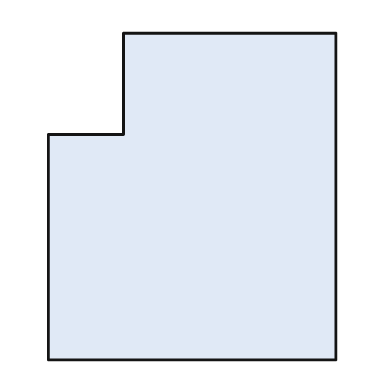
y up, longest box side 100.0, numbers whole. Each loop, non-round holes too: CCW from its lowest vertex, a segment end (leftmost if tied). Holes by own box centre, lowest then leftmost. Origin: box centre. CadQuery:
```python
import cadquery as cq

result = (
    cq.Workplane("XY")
    .moveTo(-44.0, -50.0)
    .lineTo(44.0, -50.0)
    .lineTo(44.0, 50.0)
    .lineTo(-21.0, 50.0)
    .lineTo(-21.0, 19.0)
    .lineTo(-44.0, 19.0)
    .close()
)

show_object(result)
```